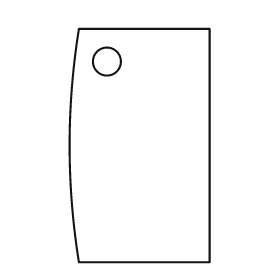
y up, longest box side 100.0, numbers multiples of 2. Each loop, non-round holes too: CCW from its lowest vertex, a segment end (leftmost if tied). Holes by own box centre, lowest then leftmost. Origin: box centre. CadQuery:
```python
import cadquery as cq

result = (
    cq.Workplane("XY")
    .moveTo(-26.0, -50.0)
    .lineTo(30.0, -50.0)
    .lineTo(30.0, 50.0)
    .lineTo(-26.0, 50.0)
    .threePointArc((-30.0, 0.0), (-26.0, -50.0))
    .close()
    .moveTo(-14.0, 36.0)
    .circle(6.0)
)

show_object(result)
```